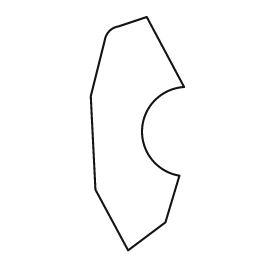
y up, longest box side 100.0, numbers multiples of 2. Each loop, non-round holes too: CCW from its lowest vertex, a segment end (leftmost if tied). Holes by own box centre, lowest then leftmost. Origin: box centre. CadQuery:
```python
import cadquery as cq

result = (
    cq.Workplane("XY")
    .moveTo(-4.0, -50.0)
    .lineTo(12.0, -38.0)
    .lineTo(18.0, -18.0)
    .threePointArc((2.0, 2.0), (20.0, 20.0))
    .lineTo(4.0, 50.0)
    .lineTo(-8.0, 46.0)
    .threePointArc((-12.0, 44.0), (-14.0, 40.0))
    .lineTo(-20.0, 16.0)
    .lineTo(-18.0, -24.0)
    .close()
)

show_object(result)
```